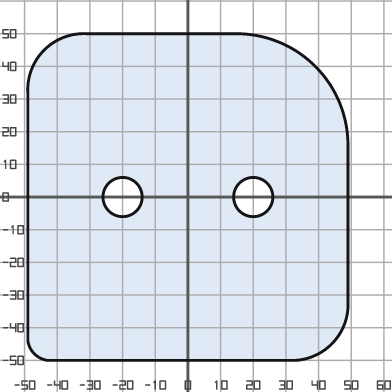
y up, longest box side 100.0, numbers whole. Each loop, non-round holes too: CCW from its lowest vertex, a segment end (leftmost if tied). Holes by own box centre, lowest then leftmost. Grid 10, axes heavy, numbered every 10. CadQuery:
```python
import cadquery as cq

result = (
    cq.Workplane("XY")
    .moveTo(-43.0, -50.0)
    .lineTo(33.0, -50.0)
    .threePointArc((44.0, -45.0), (49.0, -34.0))
    .lineTo(49.0, 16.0)
    .threePointArc((39.0, 40.0), (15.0, 50.0))
    .lineTo(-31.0, 50.0)
    .threePointArc((-44.0, 45.0), (-49.0, 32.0))
    .lineTo(-49.0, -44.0)
    .threePointArc((-47.0, -48.0), (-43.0, -50.0))
    .close()
    .moveTo(-20.0, 0.0)
    .circle(6.0)
    .moveTo(20.0, 0.0)
    .circle(6.0)
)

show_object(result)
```